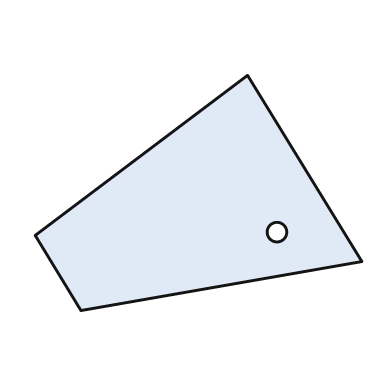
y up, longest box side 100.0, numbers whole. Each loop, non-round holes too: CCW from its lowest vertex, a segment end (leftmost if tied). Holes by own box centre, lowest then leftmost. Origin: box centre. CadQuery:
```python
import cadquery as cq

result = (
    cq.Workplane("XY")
    .moveTo(-36.0, -36.0)
    .lineTo(50.0, -21.0)
    .lineTo(15.0, 36.0)
    .lineTo(-50.0, -13.0)
    .close()
    .moveTo(24.0, -12.0)
    .circle(3.0)
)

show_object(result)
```